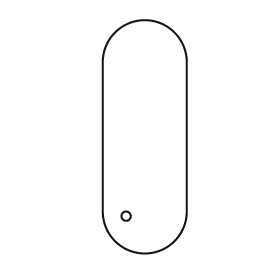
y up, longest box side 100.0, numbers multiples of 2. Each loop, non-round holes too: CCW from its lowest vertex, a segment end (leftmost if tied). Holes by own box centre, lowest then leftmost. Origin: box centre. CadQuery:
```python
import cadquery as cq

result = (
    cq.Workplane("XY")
    .moveTo(-18.0, -32.0)
    .threePointArc((0.0, -50.0), (18.0, -32.0))
    .lineTo(18.0, 32.0)
    .threePointArc((0.0, 50.0), (-18.0, 32.0))
    .close()
    .moveTo(-8.0, -34.0)
    .circle(2.0)
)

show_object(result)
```